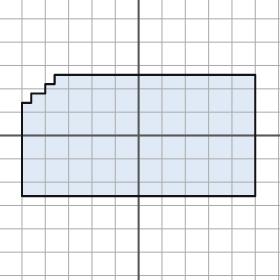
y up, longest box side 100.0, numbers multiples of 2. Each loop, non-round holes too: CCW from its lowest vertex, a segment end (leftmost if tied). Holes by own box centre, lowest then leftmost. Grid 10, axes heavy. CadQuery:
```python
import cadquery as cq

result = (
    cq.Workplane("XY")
    .moveTo(-50.0, -26.0)
    .lineTo(50.0, -26.0)
    .lineTo(50.0, 26.0)
    .lineTo(-36.0, 26.0)
    .lineTo(-36.0, 22.0)
    .lineTo(-40.0, 22.0)
    .lineTo(-40.0, 18.0)
    .lineTo(-46.0, 18.0)
    .lineTo(-46.0, 14.0)
    .lineTo(-50.0, 14.0)
    .close()
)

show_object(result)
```